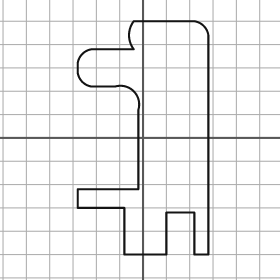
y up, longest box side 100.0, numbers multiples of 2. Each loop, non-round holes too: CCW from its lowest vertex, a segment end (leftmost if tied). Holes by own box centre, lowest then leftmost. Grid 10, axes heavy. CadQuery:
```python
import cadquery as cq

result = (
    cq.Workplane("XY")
    .moveTo(-8.0, -50.0)
    .lineTo(10.0, -50.0)
    .lineTo(10.0, -32.0)
    .lineTo(22.0, -32.0)
    .lineTo(22.0, -50.0)
    .lineTo(28.0, -50.0)
    .lineTo(28.0, 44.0)
    .threePointArc((26.0, 48.0), (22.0, 50.0))
    .lineTo(-4.0, 50.0)
    .threePointArc((-6.0, 44.0), (-4.0, 38.0))
    .lineTo(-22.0, 38.0)
    .threePointArc((-26.0, 36.0), (-28.0, 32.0))
    .lineTo(-28.0, 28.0)
    .threePointArc((-26.0, 24.0), (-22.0, 22.0))
    .lineTo(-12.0, 22.0)
    .threePointArc((-4.0, 20.0), (-2.0, 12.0))
    .lineTo(-2.0, -22.0)
    .lineTo(-28.0, -22.0)
    .lineTo(-28.0, -30.0)
    .lineTo(-8.0, -30.0)
    .close()
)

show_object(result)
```